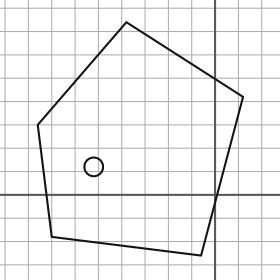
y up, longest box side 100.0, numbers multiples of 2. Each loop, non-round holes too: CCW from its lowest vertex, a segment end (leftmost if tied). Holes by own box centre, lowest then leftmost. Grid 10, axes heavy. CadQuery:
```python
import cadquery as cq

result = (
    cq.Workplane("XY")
    .moveTo(-6.0, -26.0)
    .lineTo(12.0, 42.0)
    .lineTo(-38.0, 74.0)
    .lineTo(-76.0, 30.0)
    .lineTo(-70.0, -18.0)
    .close()
    .moveTo(-52.0, 12.0)
    .circle(4.0)
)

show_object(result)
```